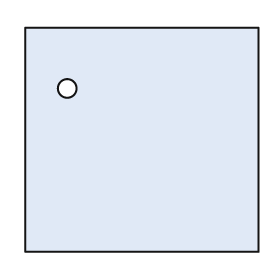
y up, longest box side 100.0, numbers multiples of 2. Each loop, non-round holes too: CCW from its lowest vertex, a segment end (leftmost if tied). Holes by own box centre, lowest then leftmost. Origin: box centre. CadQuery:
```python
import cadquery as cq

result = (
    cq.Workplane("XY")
    .moveTo(-50.0, -48.0)
    .lineTo(50.0, -48.0)
    .lineTo(50.0, 48.0)
    .lineTo(-50.0, 48.0)
    .close()
    .moveTo(-32.0, 22.0)
    .circle(4.0)
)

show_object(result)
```